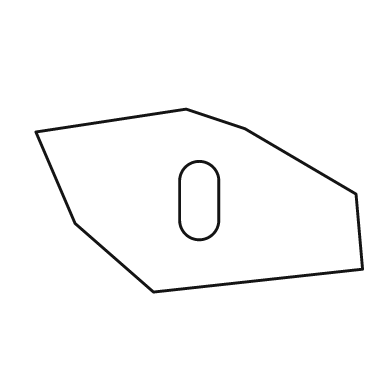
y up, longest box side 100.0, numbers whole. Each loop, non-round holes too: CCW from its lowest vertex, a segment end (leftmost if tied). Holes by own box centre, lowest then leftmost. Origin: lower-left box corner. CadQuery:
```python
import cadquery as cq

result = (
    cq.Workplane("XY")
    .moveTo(36.0, 0.0)
    .lineTo(100.0, 7.0)
    .lineTo(98.0, 30.0)
    .lineTo(64.0, 50.0)
    .lineTo(46.0, 56.0)
    .lineTo(0.0, 49.0)
    .lineTo(12.0, 21.0)
    .close()
    .moveTo(44.0, 22.0)
    .threePointArc((50.0, 16.0), (56.0, 22.0))
    .lineTo(56.0, 34.0)
    .threePointArc((50.0, 40.0), (44.0, 34.0))
    .close()
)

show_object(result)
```